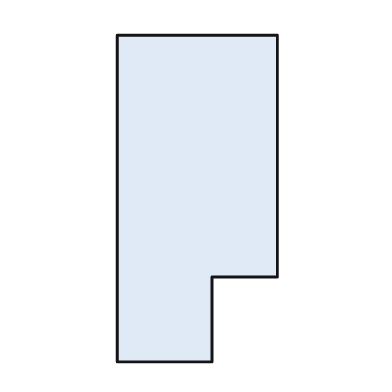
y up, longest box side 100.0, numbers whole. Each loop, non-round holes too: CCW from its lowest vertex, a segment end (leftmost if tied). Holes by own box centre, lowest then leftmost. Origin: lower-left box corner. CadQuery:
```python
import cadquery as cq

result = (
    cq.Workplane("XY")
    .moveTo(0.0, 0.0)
    .lineTo(29.0, 0.0)
    .lineTo(29.0, 26.0)
    .lineTo(49.0, 26.0)
    .lineTo(49.0, 100.0)
    .lineTo(0.0, 100.0)
    .close()
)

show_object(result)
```